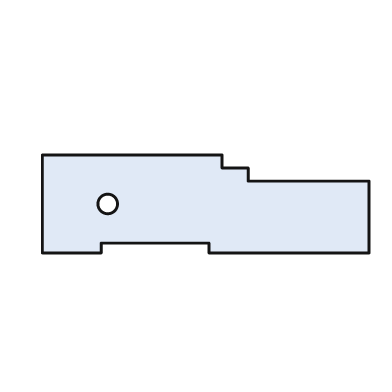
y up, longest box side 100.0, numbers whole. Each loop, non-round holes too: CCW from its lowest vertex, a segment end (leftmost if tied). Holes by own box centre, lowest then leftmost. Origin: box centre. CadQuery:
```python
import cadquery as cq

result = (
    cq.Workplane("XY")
    .moveTo(-50.0, -15.0)
    .lineTo(-32.0, -15.0)
    .lineTo(-32.0, -12.0)
    .lineTo(1.0, -12.0)
    .lineTo(1.0, -15.0)
    .lineTo(50.0, -15.0)
    .lineTo(50.0, 7.0)
    .lineTo(13.0, 7.0)
    .lineTo(13.0, 11.0)
    .lineTo(5.0, 11.0)
    .lineTo(5.0, 15.0)
    .lineTo(-50.0, 15.0)
    .close()
    .moveTo(-30.0, 0.0)
    .circle(3.0)
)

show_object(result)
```